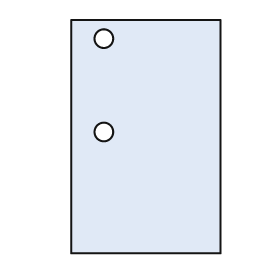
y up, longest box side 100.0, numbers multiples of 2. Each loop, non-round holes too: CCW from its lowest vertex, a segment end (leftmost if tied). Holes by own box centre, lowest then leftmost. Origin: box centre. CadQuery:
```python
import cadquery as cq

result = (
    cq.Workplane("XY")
    .moveTo(-32.0, -50.0)
    .lineTo(32.0, -50.0)
    .lineTo(32.0, 50.0)
    .lineTo(-32.0, 50.0)
    .close()
    .moveTo(-18.0, 2.0)
    .circle(4.0)
    .moveTo(-18.0, 42.0)
    .circle(4.0)
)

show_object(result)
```